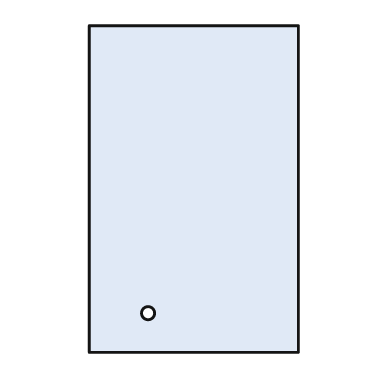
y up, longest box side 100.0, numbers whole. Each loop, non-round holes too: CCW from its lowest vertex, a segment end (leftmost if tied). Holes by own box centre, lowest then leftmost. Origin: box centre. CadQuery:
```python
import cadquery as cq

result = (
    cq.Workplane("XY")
    .moveTo(-32.0, -50.0)
    .lineTo(32.0, -50.0)
    .lineTo(32.0, 50.0)
    .lineTo(-32.0, 50.0)
    .close()
    .moveTo(-14.0, -38.0)
    .circle(2.0)
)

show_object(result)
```